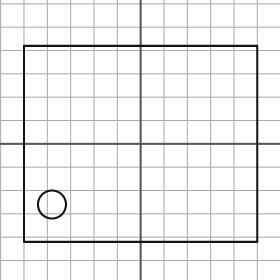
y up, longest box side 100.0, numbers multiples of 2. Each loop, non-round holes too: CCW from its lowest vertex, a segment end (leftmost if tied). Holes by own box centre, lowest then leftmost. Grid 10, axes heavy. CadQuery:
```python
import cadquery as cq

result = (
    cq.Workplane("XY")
    .moveTo(-50.0, -42.0)
    .lineTo(50.0, -42.0)
    .lineTo(50.0, 42.0)
    .lineTo(-50.0, 42.0)
    .close()
    .moveTo(-38.0, -26.0)
    .circle(6.0)
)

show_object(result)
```